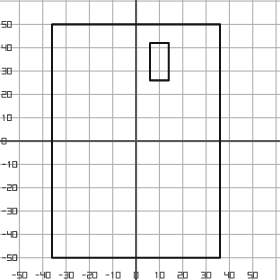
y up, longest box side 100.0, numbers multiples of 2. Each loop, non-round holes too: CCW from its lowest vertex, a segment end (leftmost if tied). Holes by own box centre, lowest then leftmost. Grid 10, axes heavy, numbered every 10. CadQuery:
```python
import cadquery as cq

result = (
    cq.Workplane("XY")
    .moveTo(-36.0, -50.0)
    .lineTo(36.0, -50.0)
    .lineTo(36.0, 50.0)
    .lineTo(-36.0, 50.0)
    .close()
    .moveTo(6.0, 26.0)
    .lineTo(14.0, 26.0)
    .lineTo(14.0, 42.0)
    .lineTo(6.0, 42.0)
    .close()
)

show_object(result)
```